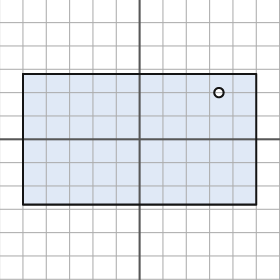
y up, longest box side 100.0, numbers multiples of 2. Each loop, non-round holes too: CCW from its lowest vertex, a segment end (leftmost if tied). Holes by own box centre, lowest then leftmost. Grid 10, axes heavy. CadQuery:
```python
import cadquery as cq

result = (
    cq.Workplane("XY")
    .moveTo(-50.0, -28.0)
    .lineTo(50.0, -28.0)
    .lineTo(50.0, 28.0)
    .lineTo(-50.0, 28.0)
    .close()
    .moveTo(34.0, 20.0)
    .circle(2.0)
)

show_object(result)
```